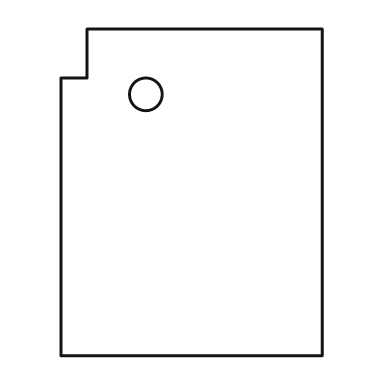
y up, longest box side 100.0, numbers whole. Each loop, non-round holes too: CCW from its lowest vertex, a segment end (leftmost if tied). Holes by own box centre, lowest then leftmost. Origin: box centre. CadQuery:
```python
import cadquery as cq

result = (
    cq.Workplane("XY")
    .moveTo(-40.0, -50.0)
    .lineTo(40.0, -50.0)
    .lineTo(40.0, 50.0)
    .lineTo(-32.0, 50.0)
    .lineTo(-32.0, 35.0)
    .lineTo(-40.0, 35.0)
    .close()
    .moveTo(-14.0, 30.0)
    .circle(5.0)
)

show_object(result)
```